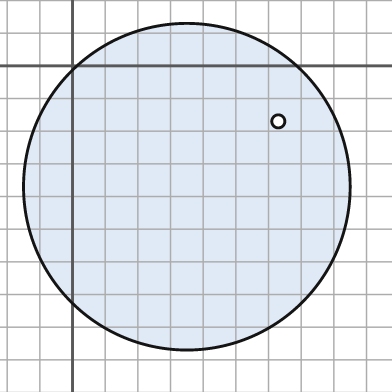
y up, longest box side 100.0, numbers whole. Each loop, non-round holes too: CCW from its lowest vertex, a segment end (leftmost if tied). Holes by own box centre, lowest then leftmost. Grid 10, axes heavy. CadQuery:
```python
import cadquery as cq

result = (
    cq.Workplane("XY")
    .moveTo(35.0, -37.0)
    .circle(50.0)
    .moveTo(63.0, -17.0)
    .circle(2.0)
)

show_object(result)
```